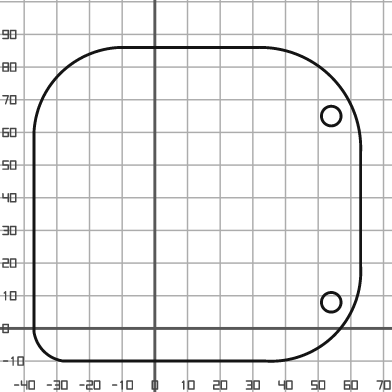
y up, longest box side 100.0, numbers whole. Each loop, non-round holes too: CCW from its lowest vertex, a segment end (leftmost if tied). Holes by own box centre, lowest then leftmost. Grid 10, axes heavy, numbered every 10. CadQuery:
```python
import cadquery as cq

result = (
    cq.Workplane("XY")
    .moveTo(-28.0, -10.0)
    .lineTo(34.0, -10.0)
    .threePointArc((55.0, -2.0), (63.0, 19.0))
    .lineTo(63.0, 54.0)
    .threePointArc((54.0, 77.0), (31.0, 86.0))
    .lineTo(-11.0, 86.0)
    .threePointArc((-29.0, 78.0), (-37.0, 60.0))
    .lineTo(-37.0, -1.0)
    .threePointArc((-34.0, -7.0), (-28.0, -10.0))
    .close()
    .moveTo(54.0, 8.0)
    .circle(3.0)
    .moveTo(54.0, 65.0)
    .circle(3.0)
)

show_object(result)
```